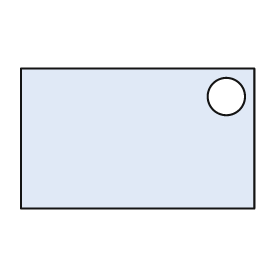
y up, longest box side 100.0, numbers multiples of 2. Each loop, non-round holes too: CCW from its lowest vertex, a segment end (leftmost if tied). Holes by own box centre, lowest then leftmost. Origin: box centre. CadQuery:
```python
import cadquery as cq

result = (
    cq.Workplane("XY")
    .moveTo(-50.0, -30.0)
    .lineTo(50.0, -30.0)
    .lineTo(50.0, 30.0)
    .lineTo(-50.0, 30.0)
    .close()
    .moveTo(38.0, 18.0)
    .circle(8.0)
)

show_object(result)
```